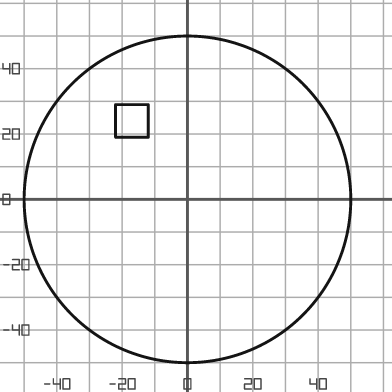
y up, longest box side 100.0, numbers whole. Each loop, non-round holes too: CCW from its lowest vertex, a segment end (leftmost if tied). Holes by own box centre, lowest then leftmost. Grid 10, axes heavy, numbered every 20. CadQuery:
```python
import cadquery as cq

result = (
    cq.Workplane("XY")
    .moveTo(0.0, 0.0)
    .circle(50.0)
    .moveTo(-22.0, 19.0)
    .lineTo(-12.0, 19.0)
    .lineTo(-12.0, 29.0)
    .lineTo(-22.0, 29.0)
    .close()
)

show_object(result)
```